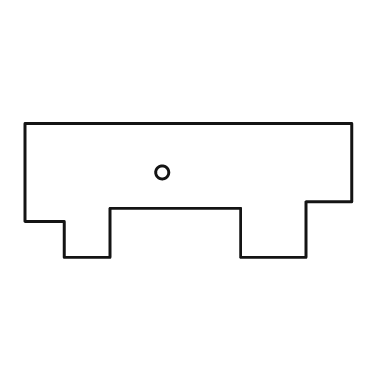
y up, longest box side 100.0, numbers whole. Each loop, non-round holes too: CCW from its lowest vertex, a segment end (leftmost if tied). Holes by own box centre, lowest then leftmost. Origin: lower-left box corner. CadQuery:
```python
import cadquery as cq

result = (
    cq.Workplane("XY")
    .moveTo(12.0, 0.0)
    .lineTo(26.0, 0.0)
    .lineTo(26.0, 15.0)
    .lineTo(66.0, 15.0)
    .lineTo(66.0, 0.0)
    .lineTo(86.0, 0.0)
    .lineTo(86.0, 17.0)
    .lineTo(100.0, 17.0)
    .lineTo(100.0, 41.0)
    .lineTo(0.0, 41.0)
    .lineTo(0.0, 11.0)
    .lineTo(12.0, 11.0)
    .close()
    .moveTo(42.0, 26.0)
    .circle(2.0)
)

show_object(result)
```